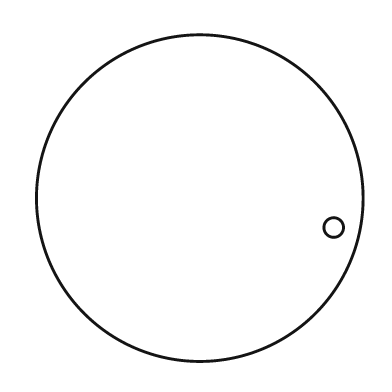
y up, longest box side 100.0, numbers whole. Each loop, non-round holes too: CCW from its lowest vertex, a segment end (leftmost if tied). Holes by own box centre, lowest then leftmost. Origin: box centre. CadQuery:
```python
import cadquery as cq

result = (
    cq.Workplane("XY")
    .moveTo(0.0, 0.0)
    .circle(50.0)
    .moveTo(41.0, -9.0)
    .circle(3.0)
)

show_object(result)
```